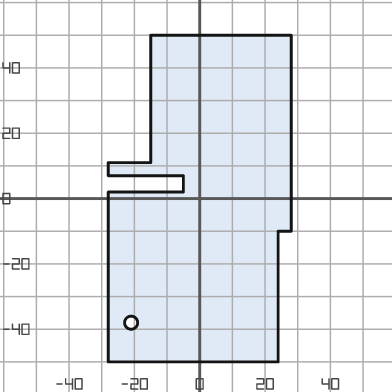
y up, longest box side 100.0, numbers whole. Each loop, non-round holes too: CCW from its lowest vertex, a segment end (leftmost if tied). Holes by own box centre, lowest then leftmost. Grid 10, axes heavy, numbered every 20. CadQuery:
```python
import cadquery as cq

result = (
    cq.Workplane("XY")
    .moveTo(-28.0, -50.0)
    .lineTo(24.0, -50.0)
    .lineTo(24.0, -10.0)
    .lineTo(28.0, -10.0)
    .lineTo(28.0, 50.0)
    .lineTo(-15.0, 50.0)
    .lineTo(-15.0, 11.0)
    .lineTo(-28.0, 11.0)
    .lineTo(-28.0, 7.0)
    .lineTo(-5.0, 7.0)
    .lineTo(-5.0, 2.0)
    .lineTo(-28.0, 2.0)
    .close()
    .moveTo(-21.0, -38.0)
    .circle(2.0)
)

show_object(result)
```